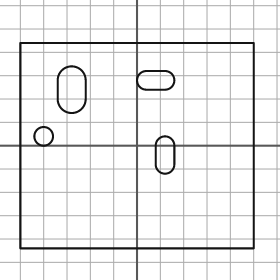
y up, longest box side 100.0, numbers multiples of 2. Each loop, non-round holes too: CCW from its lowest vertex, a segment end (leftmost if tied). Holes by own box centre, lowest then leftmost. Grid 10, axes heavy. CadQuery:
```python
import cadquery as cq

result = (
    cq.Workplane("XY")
    .moveTo(-50.0, -44.0)
    .lineTo(50.0, -44.0)
    .lineTo(50.0, 44.0)
    .lineTo(-50.0, 44.0)
    .close()
    .moveTo(8.0, -8.0)
    .threePointArc((12.0, -12.0), (16.0, -8.0))
    .lineTo(16.0, 0.0)
    .threePointArc((12.0, 4.0), (8.0, 0.0))
    .close()
    .moveTo(-40.0, 4.0)
    .circle(4.0)
    .moveTo(-34.0, 20.0)
    .threePointArc((-28.0, 14.0), (-22.0, 20.0))
    .lineTo(-22.0, 28.0)
    .threePointArc((-28.0, 34.0), (-34.0, 28.0))
    .close()
    .moveTo(4.0, 24.0)
    .lineTo(12.0, 24.0)
    .threePointArc((16.0, 28.0), (12.0, 32.0))
    .lineTo(4.0, 32.0)
    .threePointArc((0.0, 28.0), (4.0, 24.0))
    .close()
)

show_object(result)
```